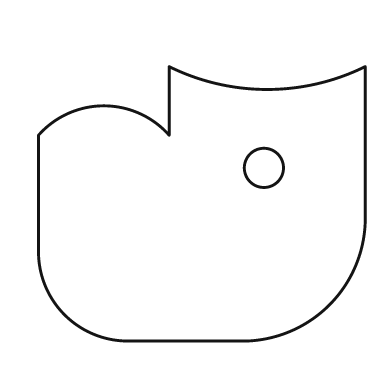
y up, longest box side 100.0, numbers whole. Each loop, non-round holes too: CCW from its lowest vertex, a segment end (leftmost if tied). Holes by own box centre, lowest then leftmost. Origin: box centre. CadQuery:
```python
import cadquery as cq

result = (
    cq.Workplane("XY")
    .moveTo(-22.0, -42.0)
    .lineTo(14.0, -42.0)
    .threePointArc((39.0, -31.0), (50.0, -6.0))
    .lineTo(50.0, 42.0)
    .threePointArc((20.0, 35.0), (-10.0, 42.0))
    .lineTo(-10.0, 21.0)
    .threePointArc((-30.0, 30.0), (-50.0, 21.0))
    .lineTo(-50.0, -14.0)
    .threePointArc((-42.0, -34.0), (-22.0, -42.0))
    .close()
    .moveTo(19.0, 11.0)
    .circle(6.0)
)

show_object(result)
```